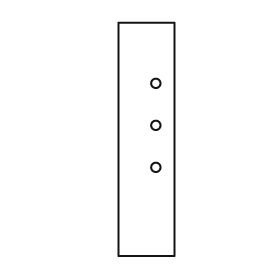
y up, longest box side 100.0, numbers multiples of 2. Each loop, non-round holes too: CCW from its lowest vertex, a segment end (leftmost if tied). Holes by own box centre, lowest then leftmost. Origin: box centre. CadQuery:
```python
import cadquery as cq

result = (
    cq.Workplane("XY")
    .moveTo(-12.0, -50.0)
    .lineTo(12.0, -50.0)
    .lineTo(12.0, 50.0)
    .lineTo(-12.0, 50.0)
    .close()
    .moveTo(4.0, -12.0)
    .circle(2.0)
    .moveTo(4.0, 6.0)
    .circle(2.0)
    .moveTo(4.0, 24.0)
    .circle(2.0)
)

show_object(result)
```